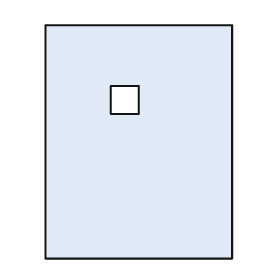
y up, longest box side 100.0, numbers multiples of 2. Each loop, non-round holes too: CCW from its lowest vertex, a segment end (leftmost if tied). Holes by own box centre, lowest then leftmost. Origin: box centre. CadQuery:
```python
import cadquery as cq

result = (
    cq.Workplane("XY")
    .moveTo(-40.0, -50.0)
    .lineTo(40.0, -50.0)
    .lineTo(40.0, 50.0)
    .lineTo(-40.0, 50.0)
    .close()
    .moveTo(-12.0, 12.0)
    .lineTo(0.0, 12.0)
    .lineTo(0.0, 24.0)
    .lineTo(-12.0, 24.0)
    .close()
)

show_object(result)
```